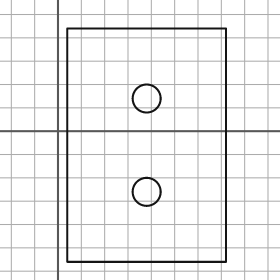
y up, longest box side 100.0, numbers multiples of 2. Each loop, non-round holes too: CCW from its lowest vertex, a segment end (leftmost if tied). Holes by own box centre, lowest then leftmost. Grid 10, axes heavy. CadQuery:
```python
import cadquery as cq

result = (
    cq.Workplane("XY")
    .moveTo(4.0, -56.0)
    .lineTo(72.0, -56.0)
    .lineTo(72.0, 44.0)
    .lineTo(4.0, 44.0)
    .close()
    .moveTo(38.0, -26.0)
    .circle(6.0)
    .moveTo(38.0, 14.0)
    .circle(6.0)
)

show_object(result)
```